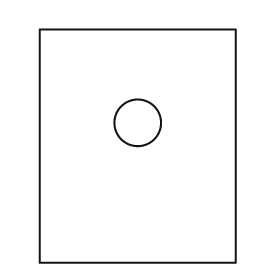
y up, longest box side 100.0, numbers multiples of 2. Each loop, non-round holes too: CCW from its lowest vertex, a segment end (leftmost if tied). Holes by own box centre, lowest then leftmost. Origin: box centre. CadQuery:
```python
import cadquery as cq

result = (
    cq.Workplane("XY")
    .moveTo(-42.0, -50.0)
    .lineTo(42.0, -50.0)
    .lineTo(42.0, 50.0)
    .lineTo(-42.0, 50.0)
    .close()
    .moveTo(0.0, 10.0)
    .circle(10.0)
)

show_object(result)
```